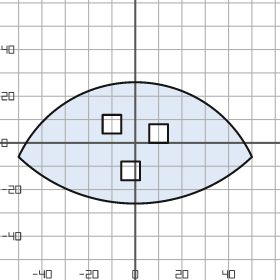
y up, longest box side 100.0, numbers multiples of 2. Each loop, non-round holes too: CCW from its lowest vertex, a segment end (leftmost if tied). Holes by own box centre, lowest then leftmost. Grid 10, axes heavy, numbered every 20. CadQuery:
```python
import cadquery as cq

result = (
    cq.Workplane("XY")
    .moveTo(-50.0, -6.0)
    .threePointArc((0.0, -26.0), (50.0, -6.0))
    .threePointArc((0.0, 26.0), (-50.0, -6.0))
    .close()
    .moveTo(-6.0, -16.0)
    .lineTo(2.0, -16.0)
    .lineTo(2.0, -8.0)
    .lineTo(-6.0, -8.0)
    .close()
    .moveTo(6.0, 0.0)
    .lineTo(14.0, 0.0)
    .lineTo(14.0, 8.0)
    .lineTo(6.0, 8.0)
    .close()
    .moveTo(-14.0, 4.0)
    .lineTo(-6.0, 4.0)
    .lineTo(-6.0, 12.0)
    .lineTo(-14.0, 12.0)
    .close()
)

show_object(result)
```